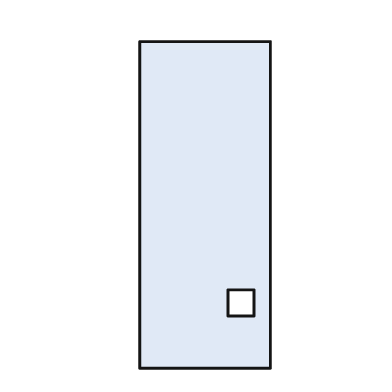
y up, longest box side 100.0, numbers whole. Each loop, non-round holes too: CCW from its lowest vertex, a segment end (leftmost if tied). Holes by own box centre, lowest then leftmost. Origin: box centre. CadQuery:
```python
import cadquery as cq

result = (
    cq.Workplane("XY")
    .moveTo(-20.0, -50.0)
    .lineTo(20.0, -50.0)
    .lineTo(20.0, 50.0)
    .lineTo(-20.0, 50.0)
    .close()
    .moveTo(7.0, -34.0)
    .lineTo(15.0, -34.0)
    .lineTo(15.0, -26.0)
    .lineTo(7.0, -26.0)
    .close()
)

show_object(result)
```